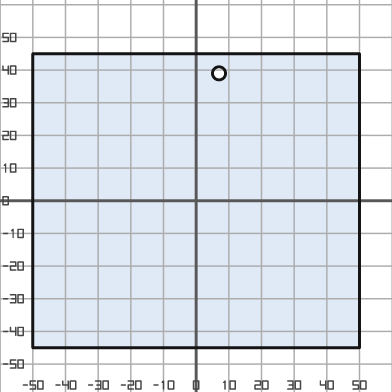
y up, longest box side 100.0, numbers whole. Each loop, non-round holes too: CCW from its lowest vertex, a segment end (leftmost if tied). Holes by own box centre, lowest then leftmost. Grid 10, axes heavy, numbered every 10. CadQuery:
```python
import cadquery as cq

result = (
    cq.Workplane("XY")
    .moveTo(-50.0, -45.0)
    .lineTo(50.0, -45.0)
    .lineTo(50.0, 45.0)
    .lineTo(-50.0, 45.0)
    .close()
    .moveTo(7.0, 39.0)
    .circle(2.0)
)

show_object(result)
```